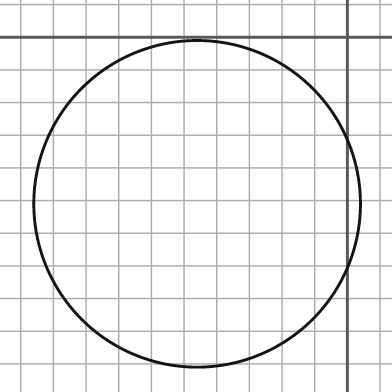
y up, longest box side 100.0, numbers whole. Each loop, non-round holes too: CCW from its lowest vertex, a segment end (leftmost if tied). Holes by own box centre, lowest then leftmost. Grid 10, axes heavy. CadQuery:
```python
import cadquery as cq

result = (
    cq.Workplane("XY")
    .moveTo(-46.0, -51.0)
    .circle(50.0)
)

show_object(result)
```